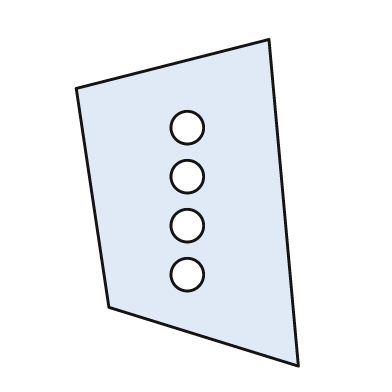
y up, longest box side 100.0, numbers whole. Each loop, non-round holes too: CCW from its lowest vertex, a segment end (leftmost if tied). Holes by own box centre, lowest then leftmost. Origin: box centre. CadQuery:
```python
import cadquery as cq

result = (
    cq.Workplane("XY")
    .moveTo(34.0, -50.0)
    .lineTo(25.0, 50.0)
    .lineTo(-34.0, 35.0)
    .lineTo(-24.0, -32.0)
    .close()
    .moveTo(0.0, -22.0)
    .circle(5.0)
    .moveTo(0.0, -7.0)
    .circle(5.0)
    .moveTo(0.0, 8.0)
    .circle(5.0)
    .moveTo(0.0, 23.0)
    .circle(5.0)
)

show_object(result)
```